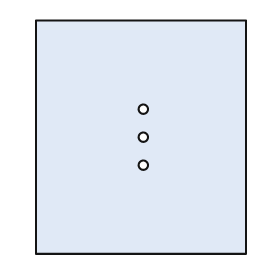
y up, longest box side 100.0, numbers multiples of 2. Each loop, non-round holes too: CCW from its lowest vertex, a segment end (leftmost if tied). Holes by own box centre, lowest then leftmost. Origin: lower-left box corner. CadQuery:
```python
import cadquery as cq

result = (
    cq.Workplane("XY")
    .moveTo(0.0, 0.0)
    .lineTo(90.0, 0.0)
    .lineTo(90.0, 100.0)
    .lineTo(0.0, 100.0)
    .close()
    .moveTo(46.0, 38.0)
    .circle(2.0)
    .moveTo(46.0, 50.0)
    .circle(2.0)
    .moveTo(46.0, 62.0)
    .circle(2.0)
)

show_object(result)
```